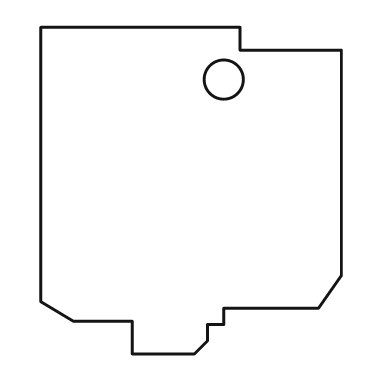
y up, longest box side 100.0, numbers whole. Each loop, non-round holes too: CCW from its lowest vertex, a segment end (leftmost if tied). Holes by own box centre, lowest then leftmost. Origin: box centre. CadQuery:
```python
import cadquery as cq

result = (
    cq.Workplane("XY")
    .moveTo(-18.0, -50.0)
    .lineTo(1.0, -50.0)
    .lineTo(5.0, -46.0)
    .lineTo(5.0, -41.0)
    .lineTo(10.0, -41.0)
    .lineTo(10.0, -36.0)
    .lineTo(39.0, -36.0)
    .lineTo(46.0, -26.0)
    .lineTo(46.0, 43.0)
    .lineTo(15.0, 43.0)
    .lineTo(15.0, 50.0)
    .lineTo(-46.0, 50.0)
    .lineTo(-46.0, -34.0)
    .lineTo(-36.0, -40.0)
    .lineTo(-18.0, -40.0)
    .close()
    .moveTo(10.0, 34.0)
    .circle(6.0)
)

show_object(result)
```